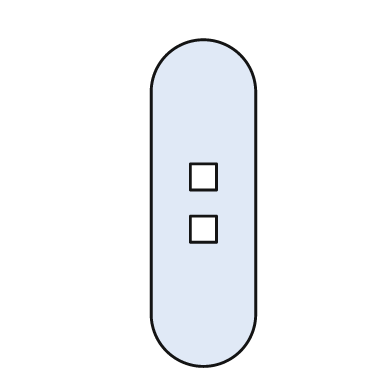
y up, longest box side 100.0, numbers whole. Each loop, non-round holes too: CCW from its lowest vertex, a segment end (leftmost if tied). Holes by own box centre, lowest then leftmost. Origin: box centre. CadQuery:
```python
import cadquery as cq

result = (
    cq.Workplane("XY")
    .moveTo(-16.0, -34.0)
    .threePointArc((0.0, -50.0), (16.0, -34.0))
    .lineTo(16.0, 34.0)
    .threePointArc((0.0, 50.0), (-16.0, 34.0))
    .close()
    .moveTo(-4.0, -12.0)
    .lineTo(4.0, -12.0)
    .lineTo(4.0, -4.0)
    .lineTo(-4.0, -4.0)
    .close()
    .moveTo(-4.0, 4.0)
    .lineTo(4.0, 4.0)
    .lineTo(4.0, 12.0)
    .lineTo(-4.0, 12.0)
    .close()
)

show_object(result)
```